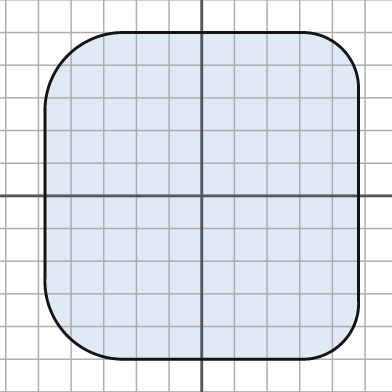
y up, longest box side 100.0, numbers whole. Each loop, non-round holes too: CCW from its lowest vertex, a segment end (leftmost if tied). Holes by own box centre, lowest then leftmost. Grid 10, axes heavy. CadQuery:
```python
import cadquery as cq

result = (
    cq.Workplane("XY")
    .moveTo(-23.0, -50.0)
    .lineTo(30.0, -50.0)
    .threePointArc((43.0, -45.0), (48.0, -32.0))
    .lineTo(48.0, 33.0)
    .threePointArc((43.0, 45.0), (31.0, 50.0))
    .lineTo(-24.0, 50.0)
    .threePointArc((-41.0, 43.0), (-48.0, 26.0))
    .lineTo(-48.0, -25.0)
    .threePointArc((-41.0, -43.0), (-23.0, -50.0))
    .close()
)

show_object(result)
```